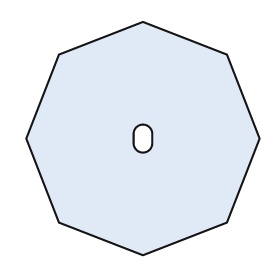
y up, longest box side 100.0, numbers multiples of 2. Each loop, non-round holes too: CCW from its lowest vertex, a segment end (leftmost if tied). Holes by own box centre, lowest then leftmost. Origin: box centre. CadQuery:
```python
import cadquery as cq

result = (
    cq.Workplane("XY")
    .moveTo(0.0, -50.0)
    .lineTo(36.0, -36.0)
    .lineTo(50.0, 0.0)
    .lineTo(36.0, 36.0)
    .lineTo(0.0, 50.0)
    .lineTo(-36.0, 36.0)
    .lineTo(-50.0, 0.0)
    .lineTo(-36.0, -36.0)
    .close()
    .moveTo(-4.0, -2.0)
    .threePointArc((0.0, -6.0), (4.0, -2.0))
    .lineTo(4.0, 2.0)
    .threePointArc((0.0, 6.0), (-4.0, 2.0))
    .close()
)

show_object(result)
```